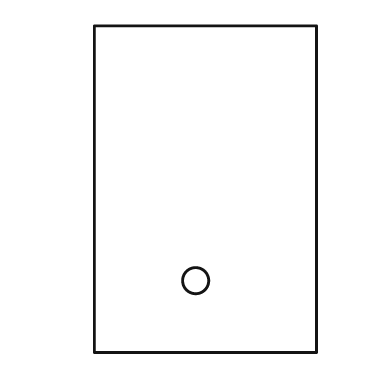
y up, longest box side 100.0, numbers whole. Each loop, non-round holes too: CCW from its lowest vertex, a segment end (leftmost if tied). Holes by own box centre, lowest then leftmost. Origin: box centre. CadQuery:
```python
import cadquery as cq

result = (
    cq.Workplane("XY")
    .moveTo(-34.0, -50.0)
    .lineTo(34.0, -50.0)
    .lineTo(34.0, 50.0)
    .lineTo(-34.0, 50.0)
    .close()
    .moveTo(-3.0, -28.0)
    .circle(4.0)
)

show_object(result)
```